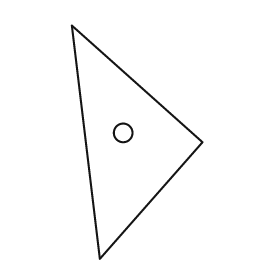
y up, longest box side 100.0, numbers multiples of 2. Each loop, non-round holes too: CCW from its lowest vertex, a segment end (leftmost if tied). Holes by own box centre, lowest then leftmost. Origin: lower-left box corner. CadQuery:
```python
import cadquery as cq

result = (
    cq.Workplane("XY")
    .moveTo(12.0, 0.0)
    .lineTo(56.0, 50.0)
    .lineTo(0.0, 100.0)
    .close()
    .moveTo(22.0, 54.0)
    .circle(4.0)
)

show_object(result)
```